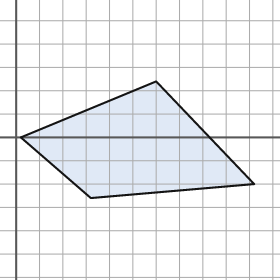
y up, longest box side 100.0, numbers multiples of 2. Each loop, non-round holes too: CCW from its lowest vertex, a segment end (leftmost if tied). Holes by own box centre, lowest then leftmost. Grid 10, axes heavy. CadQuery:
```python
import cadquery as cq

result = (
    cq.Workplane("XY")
    .moveTo(32.0, -26.0)
    .lineTo(102.0, -20.0)
    .lineTo(60.0, 24.0)
    .lineTo(2.0, 0.0)
    .close()
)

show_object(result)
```